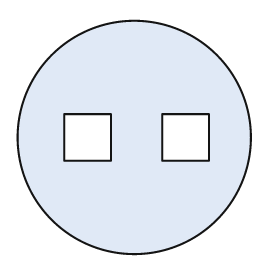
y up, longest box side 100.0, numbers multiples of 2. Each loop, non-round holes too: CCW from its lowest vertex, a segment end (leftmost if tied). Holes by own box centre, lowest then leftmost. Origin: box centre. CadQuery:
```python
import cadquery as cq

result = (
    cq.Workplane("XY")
    .moveTo(0.0, 0.0)
    .circle(50.0)
    .moveTo(-30.0, -10.0)
    .lineTo(-10.0, -10.0)
    .lineTo(-10.0, 10.0)
    .lineTo(-30.0, 10.0)
    .close()
    .moveTo(12.0, -10.0)
    .lineTo(32.0, -10.0)
    .lineTo(32.0, 10.0)
    .lineTo(12.0, 10.0)
    .close()
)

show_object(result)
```